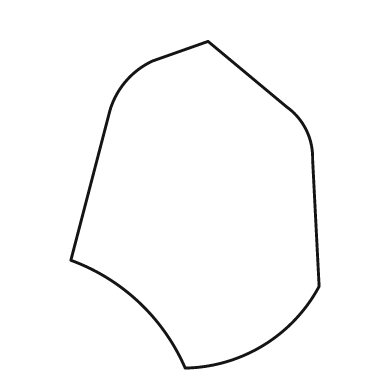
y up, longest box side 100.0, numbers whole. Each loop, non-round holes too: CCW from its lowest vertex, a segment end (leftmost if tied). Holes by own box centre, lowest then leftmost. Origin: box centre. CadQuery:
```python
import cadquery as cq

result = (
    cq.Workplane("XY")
    .moveTo(-3.0, -50.0)
    .threePointArc((21.0, -43.0), (38.0, -25.0))
    .lineTo(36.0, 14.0)
    .threePointArc((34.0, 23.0), (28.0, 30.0))
    .lineTo(4.0, 50.0)
    .lineTo(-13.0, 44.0)
    .threePointArc((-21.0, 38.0), (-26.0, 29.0))
    .lineTo(-38.0, -17.0)
    .threePointArc((-17.0, -30.0), (-3.0, -50.0))
    .close()
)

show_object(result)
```